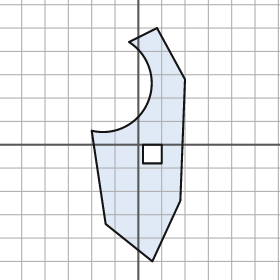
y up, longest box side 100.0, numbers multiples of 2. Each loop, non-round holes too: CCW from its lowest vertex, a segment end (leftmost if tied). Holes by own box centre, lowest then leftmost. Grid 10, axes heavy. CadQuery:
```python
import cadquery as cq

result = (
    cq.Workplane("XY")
    .moveTo(6.0, -50.0)
    .lineTo(18.0, -24.0)
    .lineTo(20.0, 28.0)
    .lineTo(8.0, 50.0)
    .lineTo(-4.0, 44.0)
    .threePointArc((4.0, 18.0), (-20.0, 6.0))
    .lineTo(-14.0, -34.0)
    .close()
    .moveTo(2.0, -8.0)
    .lineTo(10.0, -8.0)
    .lineTo(10.0, 0.0)
    .lineTo(2.0, 0.0)
    .close()
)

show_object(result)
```